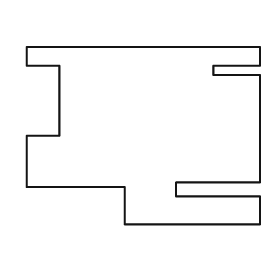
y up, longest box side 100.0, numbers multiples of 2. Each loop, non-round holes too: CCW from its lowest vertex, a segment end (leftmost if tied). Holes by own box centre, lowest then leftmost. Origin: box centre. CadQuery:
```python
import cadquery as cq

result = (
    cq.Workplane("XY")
    .moveTo(-8.0, -38.0)
    .lineTo(50.0, -38.0)
    .lineTo(50.0, -26.0)
    .lineTo(14.0, -26.0)
    .lineTo(14.0, -20.0)
    .lineTo(50.0, -20.0)
    .lineTo(50.0, 26.0)
    .lineTo(30.0, 26.0)
    .lineTo(30.0, 30.0)
    .lineTo(50.0, 30.0)
    .lineTo(50.0, 38.0)
    .lineTo(-50.0, 38.0)
    .lineTo(-50.0, 30.0)
    .lineTo(-36.0, 30.0)
    .lineTo(-36.0, 0.0)
    .lineTo(-50.0, 0.0)
    .lineTo(-50.0, -22.0)
    .lineTo(-8.0, -22.0)
    .close()
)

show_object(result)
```